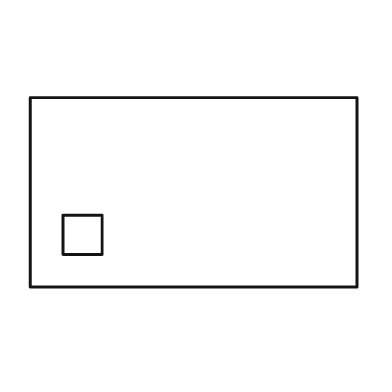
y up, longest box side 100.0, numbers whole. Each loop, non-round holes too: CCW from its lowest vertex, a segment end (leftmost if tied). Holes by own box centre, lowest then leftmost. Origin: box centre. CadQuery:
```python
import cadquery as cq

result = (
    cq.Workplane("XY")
    .moveTo(-50.0, -29.0)
    .lineTo(50.0, -29.0)
    .lineTo(50.0, 29.0)
    .lineTo(-50.0, 29.0)
    .close()
    .moveTo(-40.0, -19.0)
    .lineTo(-28.0, -19.0)
    .lineTo(-28.0, -7.0)
    .lineTo(-40.0, -7.0)
    .close()
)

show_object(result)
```